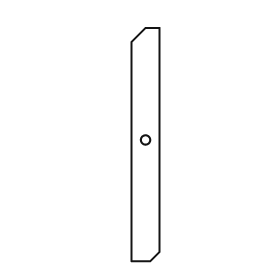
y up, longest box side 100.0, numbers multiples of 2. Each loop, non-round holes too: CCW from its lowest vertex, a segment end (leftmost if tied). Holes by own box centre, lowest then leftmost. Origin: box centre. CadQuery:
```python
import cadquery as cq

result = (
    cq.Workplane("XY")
    .moveTo(-6.0, -50.0)
    .lineTo(2.0, -50.0)
    .lineTo(6.0, -46.0)
    .lineTo(6.0, 50.0)
    .lineTo(0.0, 50.0)
    .lineTo(-6.0, 44.0)
    .close()
    .moveTo(0.0, 2.0)
    .circle(2.0)
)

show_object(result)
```